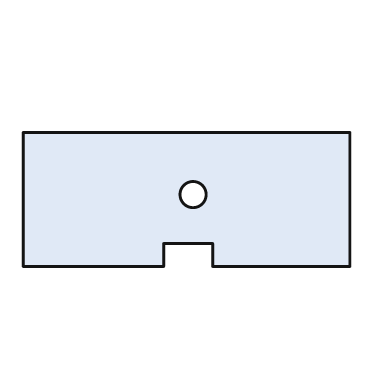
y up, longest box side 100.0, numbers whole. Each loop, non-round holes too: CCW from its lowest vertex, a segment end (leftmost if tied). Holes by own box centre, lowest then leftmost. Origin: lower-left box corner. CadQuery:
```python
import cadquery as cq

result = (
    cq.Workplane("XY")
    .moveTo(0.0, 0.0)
    .lineTo(43.0, 0.0)
    .lineTo(43.0, 7.0)
    .lineTo(58.0, 7.0)
    .lineTo(58.0, 0.0)
    .lineTo(100.0, 0.0)
    .lineTo(100.0, 41.0)
    .lineTo(0.0, 41.0)
    .close()
    .moveTo(52.0, 22.0)
    .circle(4.0)
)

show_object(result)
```